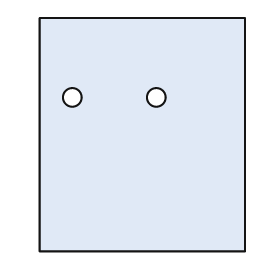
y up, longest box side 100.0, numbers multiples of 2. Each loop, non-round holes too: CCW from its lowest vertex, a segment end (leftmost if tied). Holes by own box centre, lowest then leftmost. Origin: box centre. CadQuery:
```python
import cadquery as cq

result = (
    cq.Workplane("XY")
    .moveTo(-44.0, -50.0)
    .lineTo(44.0, -50.0)
    .lineTo(44.0, 50.0)
    .lineTo(-44.0, 50.0)
    .close()
    .moveTo(-30.0, 16.0)
    .circle(4.0)
    .moveTo(6.0, 16.0)
    .circle(4.0)
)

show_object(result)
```